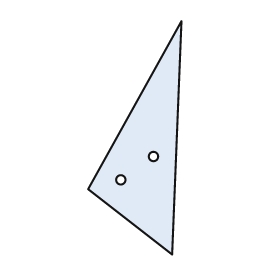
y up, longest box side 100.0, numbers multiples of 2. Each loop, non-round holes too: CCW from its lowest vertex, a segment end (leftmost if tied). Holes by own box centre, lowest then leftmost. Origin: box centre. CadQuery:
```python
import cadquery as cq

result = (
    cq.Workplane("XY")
    .moveTo(16.0, -50.0)
    .lineTo(20.0, 50.0)
    .lineTo(-20.0, -22.0)
    .close()
    .moveTo(-6.0, -18.0)
    .circle(2.0)
    .moveTo(8.0, -8.0)
    .circle(2.0)
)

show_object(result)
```